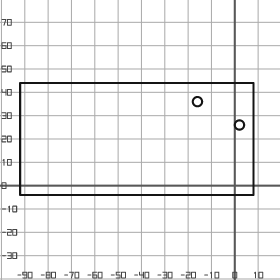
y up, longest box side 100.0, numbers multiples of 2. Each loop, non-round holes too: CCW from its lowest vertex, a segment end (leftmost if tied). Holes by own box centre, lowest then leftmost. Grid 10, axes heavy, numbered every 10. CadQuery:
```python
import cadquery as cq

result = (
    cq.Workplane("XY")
    .moveTo(-92.0, -4.0)
    .lineTo(8.0, -4.0)
    .lineTo(8.0, 44.0)
    .lineTo(-92.0, 44.0)
    .close()
    .moveTo(2.0, 26.0)
    .circle(2.0)
    .moveTo(-16.0, 36.0)
    .circle(2.0)
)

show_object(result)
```